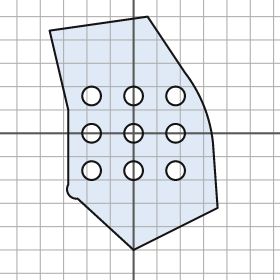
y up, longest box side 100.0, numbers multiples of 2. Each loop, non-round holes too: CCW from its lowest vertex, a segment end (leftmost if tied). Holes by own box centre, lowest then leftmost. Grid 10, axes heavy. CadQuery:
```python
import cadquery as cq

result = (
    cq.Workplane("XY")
    .moveTo(0.0, -50.0)
    .lineTo(36.0, -32.0)
    .lineTo(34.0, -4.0)
    .threePointArc((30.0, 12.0), (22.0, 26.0))
    .lineTo(6.0, 50.0)
    .lineTo(-36.0, 44.0)
    .lineTo(-28.0, 10.0)
    .lineTo(-28.0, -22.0)
    .threePointArc((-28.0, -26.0), (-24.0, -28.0))
    .close()
    .moveTo(-18.0, -16.0)
    .circle(4.0)
    .moveTo(0.0, -16.0)
    .circle(4.0)
    .moveTo(18.0, -16.0)
    .circle(4.0)
    .moveTo(-18.0, 0.0)
    .circle(4.0)
    .moveTo(0.0, 0.0)
    .circle(4.0)
    .moveTo(18.0, 0.0)
    .circle(4.0)
    .moveTo(-18.0, 16.0)
    .circle(4.0)
    .moveTo(0.0, 16.0)
    .circle(4.0)
    .moveTo(18.0, 16.0)
    .circle(4.0)
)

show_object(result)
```